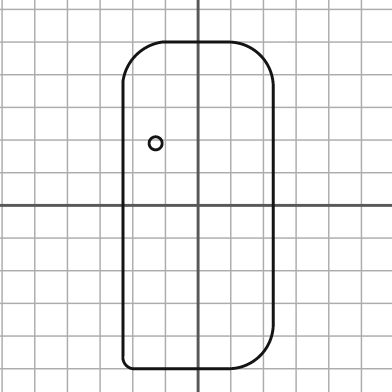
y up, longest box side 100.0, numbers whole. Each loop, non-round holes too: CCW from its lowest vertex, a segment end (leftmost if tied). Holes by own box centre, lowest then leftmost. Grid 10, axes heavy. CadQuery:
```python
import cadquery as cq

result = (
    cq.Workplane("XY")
    .moveTo(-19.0, -50.0)
    .lineTo(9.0, -50.0)
    .threePointArc((19.0, -46.0), (23.0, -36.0))
    .lineTo(23.0, 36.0)
    .threePointArc((19.0, 46.0), (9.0, 50.0))
    .lineTo(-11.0, 50.0)
    .threePointArc((-19.0, 46.0), (-23.0, 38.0))
    .lineTo(-23.0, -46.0)
    .threePointArc((-22.0, -49.0), (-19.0, -50.0))
    .close()
    .moveTo(-13.0, 19.0)
    .circle(2.0)
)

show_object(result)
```